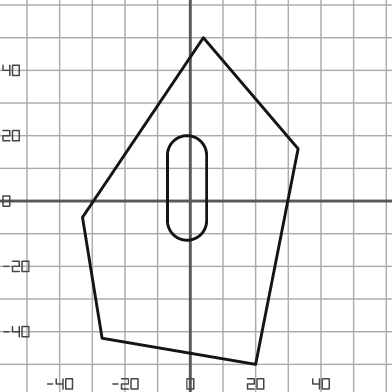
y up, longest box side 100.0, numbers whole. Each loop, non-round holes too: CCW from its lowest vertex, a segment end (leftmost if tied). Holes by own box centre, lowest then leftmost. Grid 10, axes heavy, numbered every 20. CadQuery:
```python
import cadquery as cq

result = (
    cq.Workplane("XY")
    .moveTo(20.0, -50.0)
    .lineTo(33.0, 16.0)
    .lineTo(4.0, 50.0)
    .lineTo(-33.0, -5.0)
    .lineTo(-27.0, -42.0)
    .close()
    .moveTo(-7.0, -6.0)
    .threePointArc((-1.0, -12.0), (5.0, -6.0))
    .lineTo(5.0, 14.0)
    .threePointArc((-1.0, 20.0), (-7.0, 14.0))
    .close()
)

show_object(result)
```